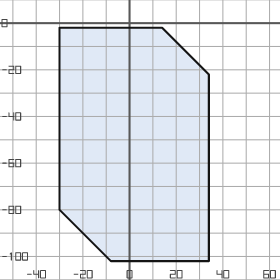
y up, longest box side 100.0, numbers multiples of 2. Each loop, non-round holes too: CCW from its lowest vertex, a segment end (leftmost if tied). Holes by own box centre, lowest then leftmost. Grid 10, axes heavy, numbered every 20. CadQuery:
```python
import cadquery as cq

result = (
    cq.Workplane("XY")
    .moveTo(-8.0, -102.0)
    .lineTo(34.0, -102.0)
    .lineTo(34.0, -22.0)
    .lineTo(14.0, -2.0)
    .lineTo(-30.0, -2.0)
    .lineTo(-30.0, -80.0)
    .close()
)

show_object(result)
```